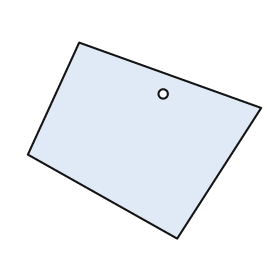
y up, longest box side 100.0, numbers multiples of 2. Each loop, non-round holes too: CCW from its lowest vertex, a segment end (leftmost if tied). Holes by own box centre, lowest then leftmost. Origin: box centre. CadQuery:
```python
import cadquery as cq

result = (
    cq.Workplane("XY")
    .moveTo(14.0, -42.0)
    .lineTo(50.0, 14.0)
    .lineTo(-28.0, 42.0)
    .lineTo(-50.0, -6.0)
    .close()
    .moveTo(8.0, 20.0)
    .circle(2.0)
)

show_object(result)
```